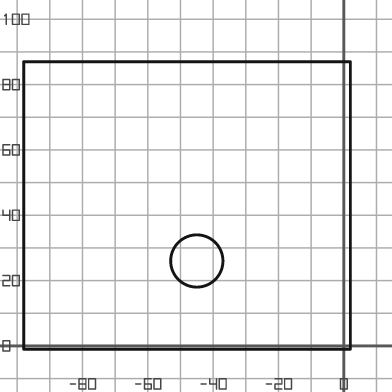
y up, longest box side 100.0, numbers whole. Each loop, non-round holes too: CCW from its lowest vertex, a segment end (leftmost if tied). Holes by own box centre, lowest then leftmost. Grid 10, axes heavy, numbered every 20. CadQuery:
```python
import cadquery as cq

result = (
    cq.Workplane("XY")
    .moveTo(-98.0, -1.0)
    .lineTo(2.0, -1.0)
    .lineTo(2.0, 87.0)
    .lineTo(-98.0, 87.0)
    .close()
    .moveTo(-45.0, 26.0)
    .circle(8.0)
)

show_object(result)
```